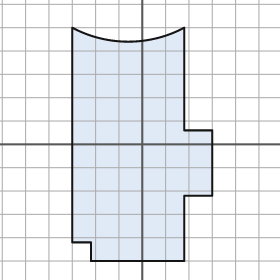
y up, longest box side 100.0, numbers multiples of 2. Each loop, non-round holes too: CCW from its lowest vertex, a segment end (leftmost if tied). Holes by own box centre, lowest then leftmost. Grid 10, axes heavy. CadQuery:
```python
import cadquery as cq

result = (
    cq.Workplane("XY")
    .moveTo(-22.0, -50.0)
    .lineTo(18.0, -50.0)
    .lineTo(18.0, -22.0)
    .lineTo(30.0, -22.0)
    .lineTo(30.0, 6.0)
    .lineTo(18.0, 6.0)
    .lineTo(18.0, 50.0)
    .threePointArc((-6.0, 44.0), (-30.0, 50.0))
    .lineTo(-30.0, -42.0)
    .lineTo(-22.0, -42.0)
    .close()
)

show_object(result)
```